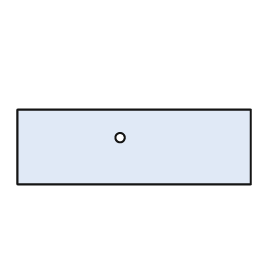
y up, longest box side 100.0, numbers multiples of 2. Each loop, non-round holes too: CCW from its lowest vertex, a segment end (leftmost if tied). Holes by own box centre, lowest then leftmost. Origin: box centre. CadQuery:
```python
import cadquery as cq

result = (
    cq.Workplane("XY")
    .moveTo(-50.0, -16.0)
    .lineTo(50.0, -16.0)
    .lineTo(50.0, 16.0)
    .lineTo(-50.0, 16.0)
    .close()
    .moveTo(-6.0, 4.0)
    .circle(2.0)
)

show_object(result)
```